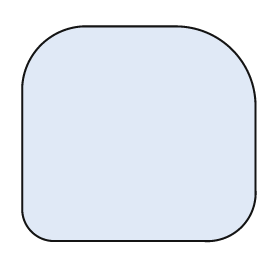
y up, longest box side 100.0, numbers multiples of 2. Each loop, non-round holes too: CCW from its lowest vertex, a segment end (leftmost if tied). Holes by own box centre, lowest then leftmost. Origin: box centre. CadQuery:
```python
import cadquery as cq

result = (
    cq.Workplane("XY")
    .moveTo(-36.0, -46.0)
    .lineTo(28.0, -46.0)
    .threePointArc((44.0, -40.0), (50.0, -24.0))
    .lineTo(50.0, 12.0)
    .threePointArc((40.0, 36.0), (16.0, 46.0))
    .lineTo(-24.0, 46.0)
    .threePointArc((-42.0, 38.0), (-50.0, 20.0))
    .lineTo(-50.0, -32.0)
    .threePointArc((-46.0, -42.0), (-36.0, -46.0))
    .close()
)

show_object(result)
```